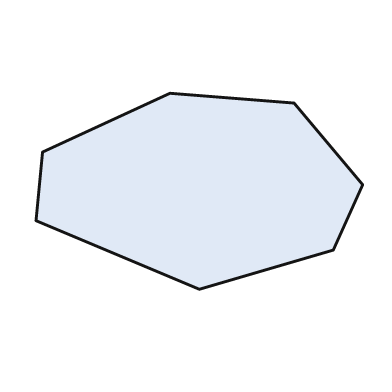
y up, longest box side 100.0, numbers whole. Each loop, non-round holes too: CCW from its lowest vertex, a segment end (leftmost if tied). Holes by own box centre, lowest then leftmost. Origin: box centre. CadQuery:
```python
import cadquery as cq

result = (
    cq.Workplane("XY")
    .moveTo(0.0, -30.0)
    .lineTo(41.0, -18.0)
    .lineTo(50.0, 2.0)
    .lineTo(29.0, 27.0)
    .lineTo(-9.0, 30.0)
    .lineTo(-48.0, 12.0)
    .lineTo(-50.0, -9.0)
    .close()
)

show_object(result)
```